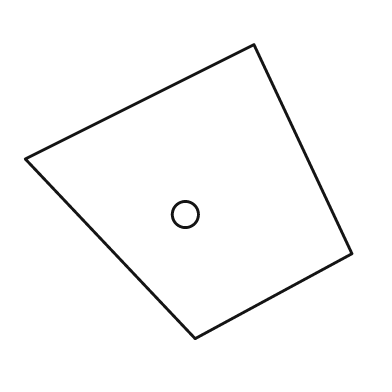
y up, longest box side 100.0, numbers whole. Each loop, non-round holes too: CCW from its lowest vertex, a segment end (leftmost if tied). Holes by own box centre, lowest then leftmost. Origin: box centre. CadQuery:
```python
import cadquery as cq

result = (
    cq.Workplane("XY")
    .moveTo(2.0, -45.0)
    .lineTo(50.0, -19.0)
    .lineTo(20.0, 45.0)
    .lineTo(-50.0, 10.0)
    .close()
    .moveTo(-1.0, -7.0)
    .circle(4.0)
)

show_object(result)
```